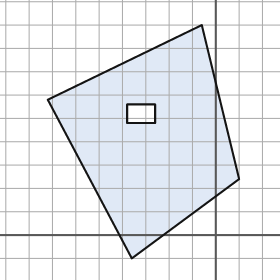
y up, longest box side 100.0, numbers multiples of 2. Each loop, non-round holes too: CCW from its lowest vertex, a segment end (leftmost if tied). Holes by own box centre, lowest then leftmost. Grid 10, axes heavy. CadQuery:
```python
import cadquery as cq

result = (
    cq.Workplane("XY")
    .moveTo(-36.0, -10.0)
    .lineTo(10.0, 24.0)
    .lineTo(-6.0, 90.0)
    .lineTo(-72.0, 58.0)
    .close()
    .moveTo(-38.0, 48.0)
    .lineTo(-26.0, 48.0)
    .lineTo(-26.0, 56.0)
    .lineTo(-38.0, 56.0)
    .close()
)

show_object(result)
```